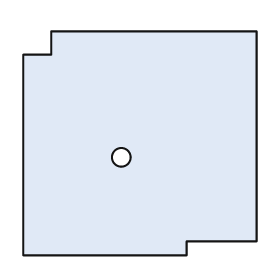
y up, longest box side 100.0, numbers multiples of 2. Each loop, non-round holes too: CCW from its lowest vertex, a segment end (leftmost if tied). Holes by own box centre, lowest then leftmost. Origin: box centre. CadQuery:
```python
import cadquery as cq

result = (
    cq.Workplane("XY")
    .moveTo(-50.0, -48.0)
    .lineTo(20.0, -48.0)
    .lineTo(20.0, -42.0)
    .lineTo(50.0, -42.0)
    .lineTo(50.0, 48.0)
    .lineTo(-38.0, 48.0)
    .lineTo(-38.0, 38.0)
    .lineTo(-50.0, 38.0)
    .close()
    .moveTo(-8.0, -6.0)
    .circle(4.0)
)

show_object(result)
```